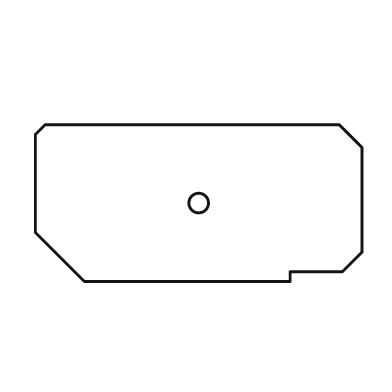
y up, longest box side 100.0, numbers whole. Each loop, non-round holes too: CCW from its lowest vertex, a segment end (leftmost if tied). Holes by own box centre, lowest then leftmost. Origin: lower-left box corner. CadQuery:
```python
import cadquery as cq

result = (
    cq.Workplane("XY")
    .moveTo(15.0, 0.0)
    .lineTo(78.0, 0.0)
    .lineTo(78.0, 3.0)
    .lineTo(94.0, 3.0)
    .lineTo(100.0, 9.0)
    .lineTo(100.0, 41.0)
    .lineTo(93.0, 48.0)
    .lineTo(3.0, 48.0)
    .lineTo(0.0, 45.0)
    .lineTo(0.0, 15.0)
    .close()
    .moveTo(50.0, 24.0)
    .circle(3.0)
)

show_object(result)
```